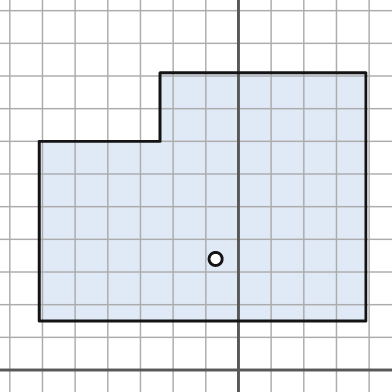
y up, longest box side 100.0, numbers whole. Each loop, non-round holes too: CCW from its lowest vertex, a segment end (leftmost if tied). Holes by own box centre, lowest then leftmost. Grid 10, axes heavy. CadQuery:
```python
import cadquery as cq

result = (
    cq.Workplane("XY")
    .moveTo(-61.0, 15.0)
    .lineTo(39.0, 15.0)
    .lineTo(39.0, 91.0)
    .lineTo(-24.0, 91.0)
    .lineTo(-24.0, 70.0)
    .lineTo(-61.0, 70.0)
    .close()
    .moveTo(-7.0, 34.0)
    .circle(2.0)
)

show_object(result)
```